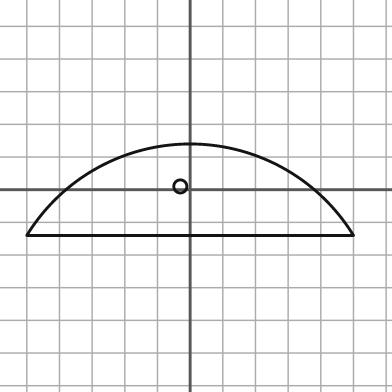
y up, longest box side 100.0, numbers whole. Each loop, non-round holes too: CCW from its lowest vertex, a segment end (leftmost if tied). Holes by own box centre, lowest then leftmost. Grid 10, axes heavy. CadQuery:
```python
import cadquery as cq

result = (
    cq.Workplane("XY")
    .moveTo(-50.0, -14.0)
    .lineTo(50.0, -14.0)
    .threePointArc((0.0, 14.0), (-50.0, -14.0))
    .close()
    .moveTo(-3.0, 1.0)
    .circle(2.0)
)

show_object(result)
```